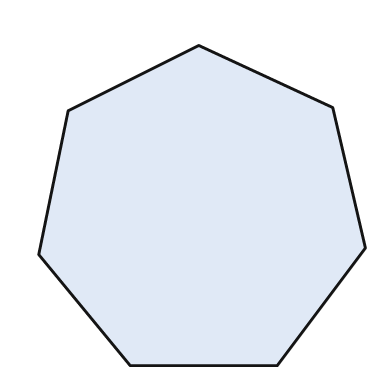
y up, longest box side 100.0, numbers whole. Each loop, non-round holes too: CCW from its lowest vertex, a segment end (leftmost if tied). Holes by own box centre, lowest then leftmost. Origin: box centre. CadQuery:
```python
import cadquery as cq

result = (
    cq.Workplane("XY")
    .moveTo(-22.0, -49.0)
    .lineTo(23.0, -49.0)
    .lineTo(50.0, -13.0)
    .lineTo(40.0, 30.0)
    .lineTo(-1.0, 49.0)
    .lineTo(-41.0, 29.0)
    .lineTo(-50.0, -15.0)
    .close()
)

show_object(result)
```